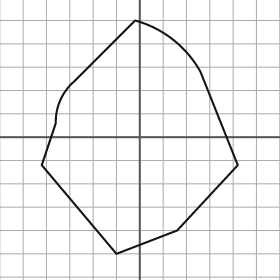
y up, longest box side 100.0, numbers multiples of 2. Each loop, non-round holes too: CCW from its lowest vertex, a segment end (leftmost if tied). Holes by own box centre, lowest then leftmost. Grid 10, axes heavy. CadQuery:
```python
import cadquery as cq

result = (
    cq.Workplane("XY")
    .moveTo(-10.0, -50.0)
    .lineTo(16.0, -40.0)
    .lineTo(42.0, -12.0)
    .lineTo(26.0, 28.0)
    .threePointArc((14.0, 42.0), (-2.0, 50.0))
    .lineTo(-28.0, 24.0)
    .threePointArc((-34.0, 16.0), (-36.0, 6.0))
    .lineTo(-42.0, -12.0)
    .close()
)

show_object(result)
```